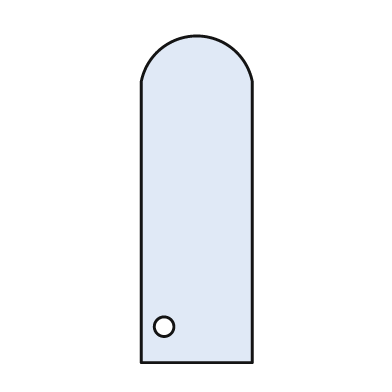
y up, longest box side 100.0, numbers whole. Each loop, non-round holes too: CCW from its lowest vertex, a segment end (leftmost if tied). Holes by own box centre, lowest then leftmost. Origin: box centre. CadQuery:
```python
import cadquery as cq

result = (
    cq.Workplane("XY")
    .moveTo(-17.0, -50.0)
    .lineTo(17.0, -50.0)
    .lineTo(17.0, 36.0)
    .threePointArc((0.0, 50.0), (-17.0, 36.0))
    .close()
    .moveTo(-10.0, -39.0)
    .circle(3.0)
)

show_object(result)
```